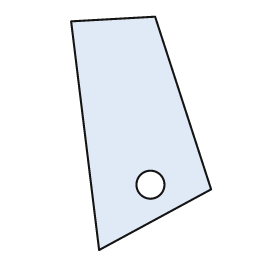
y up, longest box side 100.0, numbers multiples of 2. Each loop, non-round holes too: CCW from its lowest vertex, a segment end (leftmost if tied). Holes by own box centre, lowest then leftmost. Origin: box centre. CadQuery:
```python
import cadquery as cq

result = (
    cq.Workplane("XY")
    .moveTo(-18.0, -50.0)
    .lineTo(30.0, -24.0)
    .lineTo(6.0, 50.0)
    .lineTo(-30.0, 48.0)
    .close()
    .moveTo(4.0, -22.0)
    .circle(6.0)
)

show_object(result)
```